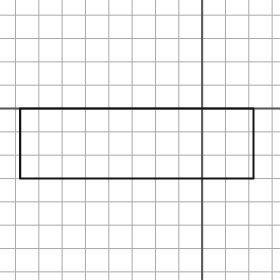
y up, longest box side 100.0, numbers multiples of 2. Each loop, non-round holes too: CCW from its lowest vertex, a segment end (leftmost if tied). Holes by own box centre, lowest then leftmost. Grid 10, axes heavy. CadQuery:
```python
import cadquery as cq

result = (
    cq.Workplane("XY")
    .moveTo(-78.0, -30.0)
    .lineTo(22.0, -30.0)
    .lineTo(22.0, 0.0)
    .lineTo(-78.0, 0.0)
    .close()
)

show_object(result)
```